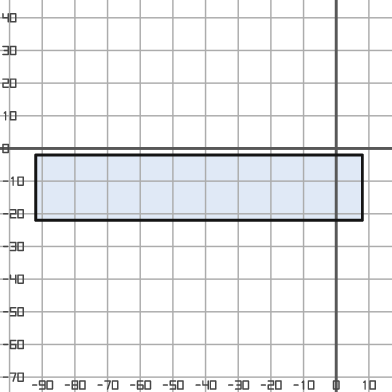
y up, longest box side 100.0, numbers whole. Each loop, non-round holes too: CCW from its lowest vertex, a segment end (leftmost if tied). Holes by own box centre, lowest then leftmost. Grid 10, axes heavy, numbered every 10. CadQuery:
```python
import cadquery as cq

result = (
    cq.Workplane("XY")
    .moveTo(-92.0, -22.0)
    .lineTo(8.0, -22.0)
    .lineTo(8.0, -2.0)
    .lineTo(-92.0, -2.0)
    .close()
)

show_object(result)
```